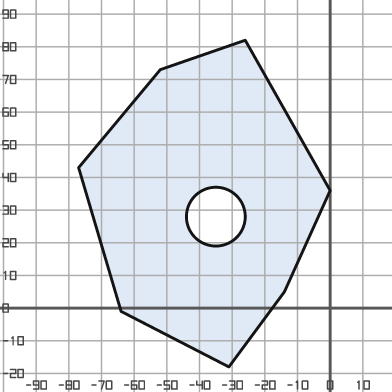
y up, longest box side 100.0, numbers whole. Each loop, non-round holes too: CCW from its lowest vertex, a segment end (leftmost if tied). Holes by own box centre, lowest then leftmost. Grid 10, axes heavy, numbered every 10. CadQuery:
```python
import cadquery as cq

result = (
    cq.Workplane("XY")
    .moveTo(-31.0, -18.0)
    .lineTo(-14.0, 5.0)
    .lineTo(0.0, 36.0)
    .lineTo(-26.0, 82.0)
    .lineTo(-52.0, 73.0)
    .lineTo(-77.0, 43.0)
    .lineTo(-64.0, -1.0)
    .close()
    .moveTo(-35.0, 28.0)
    .circle(9.0)
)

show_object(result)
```